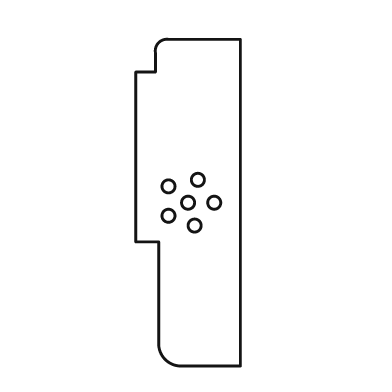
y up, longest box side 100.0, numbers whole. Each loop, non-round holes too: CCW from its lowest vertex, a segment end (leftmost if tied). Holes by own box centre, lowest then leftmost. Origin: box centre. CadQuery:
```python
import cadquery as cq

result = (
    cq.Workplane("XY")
    .moveTo(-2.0, -50.0)
    .lineTo(16.0, -50.0)
    .lineTo(16.0, 50.0)
    .lineTo(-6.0, 50.0)
    .threePointArc((-9.0, 49.0), (-10.0, 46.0))
    .lineTo(-10.0, 40.0)
    .lineTo(-16.0, 40.0)
    .lineTo(-16.0, -12.0)
    .lineTo(-9.0, -12.0)
    .lineTo(-9.0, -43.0)
    .threePointArc((-7.0, -48.0), (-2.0, -50.0))
    .close()
    .moveTo(2.0, -7.0)
    .circle(2.0)
    .moveTo(-6.0, -4.0)
    .circle(2.0)
    .moveTo(0.0, 0.0)
    .circle(2.0)
    .moveTo(8.0, 0.0)
    .circle(2.0)
    .moveTo(-6.0, 5.0)
    .circle(2.0)
    .moveTo(3.0, 7.0)
    .circle(2.0)
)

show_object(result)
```